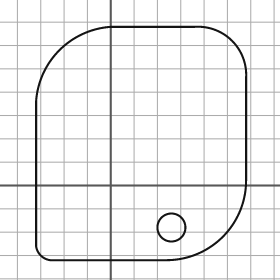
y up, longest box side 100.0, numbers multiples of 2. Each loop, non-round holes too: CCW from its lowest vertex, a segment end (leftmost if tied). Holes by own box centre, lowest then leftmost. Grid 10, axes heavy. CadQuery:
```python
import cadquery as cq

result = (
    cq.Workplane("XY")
    .moveTo(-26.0, -32.0)
    .lineTo(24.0, -32.0)
    .threePointArc((48.0, -22.0), (58.0, 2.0))
    .lineTo(58.0, 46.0)
    .threePointArc((52.0, 62.0), (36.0, 68.0))
    .lineTo(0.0, 68.0)
    .threePointArc((-22.0, 58.0), (-32.0, 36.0))
    .lineTo(-32.0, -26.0)
    .threePointArc((-30.0, -30.0), (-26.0, -32.0))
    .close()
    .moveTo(26.0, -18.0)
    .circle(6.0)
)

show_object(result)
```